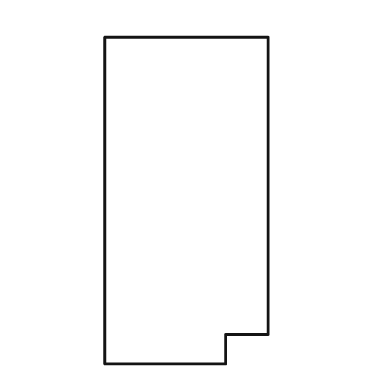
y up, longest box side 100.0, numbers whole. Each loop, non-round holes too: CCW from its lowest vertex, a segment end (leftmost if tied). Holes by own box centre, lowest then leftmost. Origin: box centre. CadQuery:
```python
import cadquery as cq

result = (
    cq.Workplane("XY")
    .moveTo(-25.0, -50.0)
    .lineTo(12.0, -50.0)
    .lineTo(12.0, -41.0)
    .lineTo(25.0, -41.0)
    .lineTo(25.0, 50.0)
    .lineTo(-25.0, 50.0)
    .close()
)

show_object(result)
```